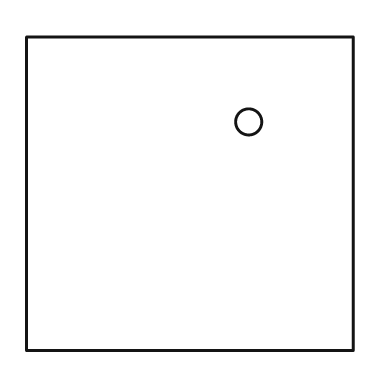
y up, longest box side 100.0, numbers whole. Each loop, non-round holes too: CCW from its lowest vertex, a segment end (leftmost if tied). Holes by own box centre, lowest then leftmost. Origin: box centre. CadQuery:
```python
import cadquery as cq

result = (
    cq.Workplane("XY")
    .moveTo(-50.0, -48.0)
    .lineTo(50.0, -48.0)
    .lineTo(50.0, 48.0)
    .lineTo(-50.0, 48.0)
    .close()
    .moveTo(18.0, 22.0)
    .circle(4.0)
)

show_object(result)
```